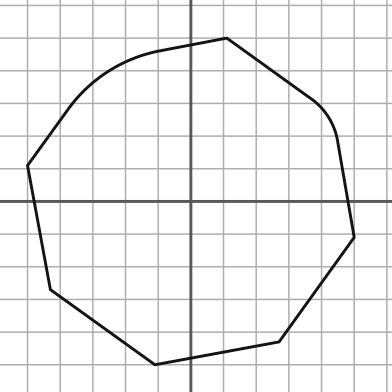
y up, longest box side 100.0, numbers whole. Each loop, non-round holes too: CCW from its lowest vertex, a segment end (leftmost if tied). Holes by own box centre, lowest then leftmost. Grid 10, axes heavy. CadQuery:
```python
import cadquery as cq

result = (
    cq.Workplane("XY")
    .moveTo(-11.0, -50.0)
    .lineTo(27.0, -43.0)
    .lineTo(50.0, -11.0)
    .lineTo(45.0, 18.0)
    .threePointArc((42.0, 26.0), (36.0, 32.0))
    .lineTo(11.0, 50.0)
    .lineTo(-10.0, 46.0)
    .threePointArc((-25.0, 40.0), (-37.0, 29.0))
    .lineTo(-50.0, 11.0)
    .lineTo(-43.0, -27.0)
    .close()
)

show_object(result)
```